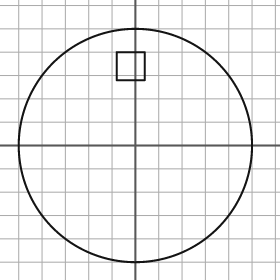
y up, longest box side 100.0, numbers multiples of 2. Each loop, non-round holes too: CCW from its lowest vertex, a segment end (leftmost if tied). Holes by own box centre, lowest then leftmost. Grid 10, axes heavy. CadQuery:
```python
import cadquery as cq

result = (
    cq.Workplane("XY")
    .moveTo(0.0, 0.0)
    .circle(50.0)
    .moveTo(-8.0, 28.0)
    .lineTo(4.0, 28.0)
    .lineTo(4.0, 40.0)
    .lineTo(-8.0, 40.0)
    .close()
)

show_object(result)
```